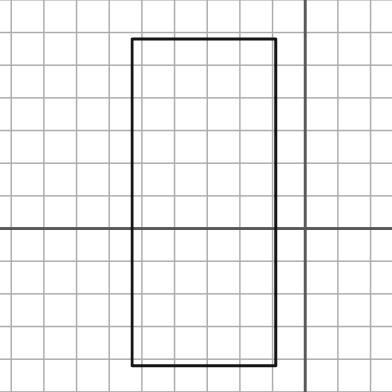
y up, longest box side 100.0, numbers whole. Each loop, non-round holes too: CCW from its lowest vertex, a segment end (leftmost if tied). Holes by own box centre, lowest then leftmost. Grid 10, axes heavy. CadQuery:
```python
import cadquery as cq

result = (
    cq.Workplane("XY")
    .moveTo(-53.0, -42.0)
    .lineTo(-9.0, -42.0)
    .lineTo(-9.0, 58.0)
    .lineTo(-53.0, 58.0)
    .close()
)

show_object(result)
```